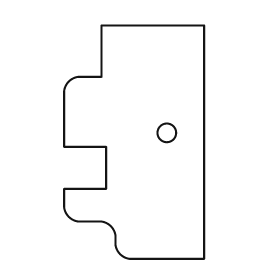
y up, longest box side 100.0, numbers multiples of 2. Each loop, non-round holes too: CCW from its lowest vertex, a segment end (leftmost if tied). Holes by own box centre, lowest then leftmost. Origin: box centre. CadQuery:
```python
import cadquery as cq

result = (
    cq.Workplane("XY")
    .moveTo(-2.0, -50.0)
    .lineTo(30.0, -50.0)
    .lineTo(30.0, 50.0)
    .lineTo(-14.0, 50.0)
    .lineTo(-14.0, 28.0)
    .lineTo(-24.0, 28.0)
    .threePointArc((-28.0, 26.0), (-30.0, 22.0))
    .lineTo(-30.0, -2.0)
    .lineTo(-12.0, -2.0)
    .lineTo(-12.0, -20.0)
    .lineTo(-30.0, -20.0)
    .lineTo(-30.0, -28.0)
    .threePointArc((-28.0, -32.0), (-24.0, -34.0))
    .lineTo(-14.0, -34.0)
    .threePointArc((-10.0, -36.0), (-8.0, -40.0))
    .lineTo(-8.0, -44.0)
    .threePointArc((-6.0, -48.0), (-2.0, -50.0))
    .close()
    .moveTo(14.0, 4.0)
    .circle(4.0)
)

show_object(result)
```